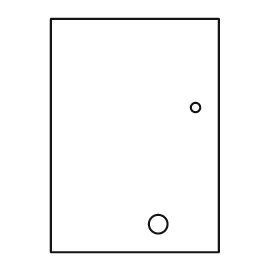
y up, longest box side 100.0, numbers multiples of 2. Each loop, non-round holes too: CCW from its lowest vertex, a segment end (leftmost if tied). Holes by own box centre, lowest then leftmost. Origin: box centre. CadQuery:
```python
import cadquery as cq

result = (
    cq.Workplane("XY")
    .moveTo(-36.0, -50.0)
    .lineTo(36.0, -50.0)
    .lineTo(36.0, 50.0)
    .lineTo(-36.0, 50.0)
    .close()
    .moveTo(10.0, -38.0)
    .circle(4.0)
    .moveTo(26.0, 12.0)
    .circle(2.0)
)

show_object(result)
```